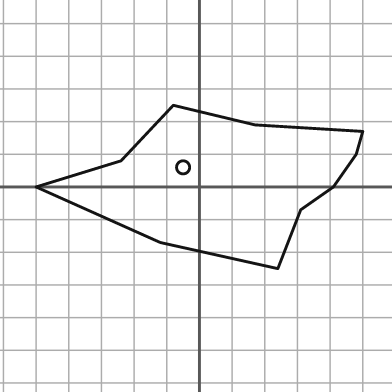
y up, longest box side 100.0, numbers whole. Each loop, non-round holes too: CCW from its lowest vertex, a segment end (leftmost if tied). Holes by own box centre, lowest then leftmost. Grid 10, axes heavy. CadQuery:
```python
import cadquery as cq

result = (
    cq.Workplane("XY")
    .moveTo(24.0, -25.0)
    .lineTo(31.0, -7.0)
    .lineTo(41.0, 0.0)
    .lineTo(48.0, 10.0)
    .lineTo(50.0, 17.0)
    .lineTo(17.0, 19.0)
    .lineTo(-8.0, 25.0)
    .lineTo(-24.0, 8.0)
    .lineTo(-50.0, 0.0)
    .lineTo(-12.0, -17.0)
    .close()
    .moveTo(-5.0, 6.0)
    .circle(2.0)
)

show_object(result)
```